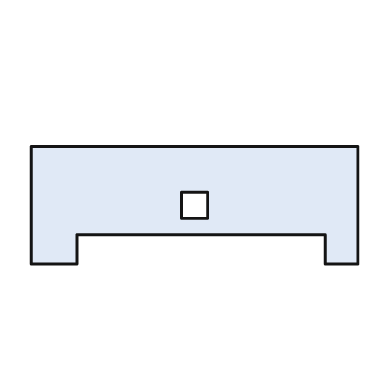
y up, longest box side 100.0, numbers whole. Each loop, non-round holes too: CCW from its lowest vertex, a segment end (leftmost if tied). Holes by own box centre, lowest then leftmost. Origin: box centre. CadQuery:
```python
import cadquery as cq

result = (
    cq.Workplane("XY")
    .moveTo(-50.0, -18.0)
    .lineTo(-36.0, -18.0)
    .lineTo(-36.0, -9.0)
    .lineTo(40.0, -9.0)
    .lineTo(40.0, -18.0)
    .lineTo(50.0, -18.0)
    .lineTo(50.0, 18.0)
    .lineTo(-50.0, 18.0)
    .close()
    .moveTo(-4.0, -4.0)
    .lineTo(4.0, -4.0)
    .lineTo(4.0, 4.0)
    .lineTo(-4.0, 4.0)
    .close()
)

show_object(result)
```